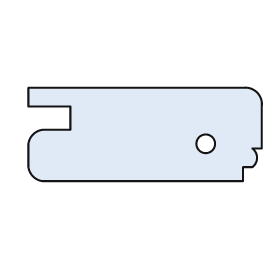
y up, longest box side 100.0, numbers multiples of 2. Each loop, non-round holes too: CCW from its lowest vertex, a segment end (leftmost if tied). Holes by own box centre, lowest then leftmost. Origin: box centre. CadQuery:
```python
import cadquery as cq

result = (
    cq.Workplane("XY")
    .moveTo(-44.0, -20.0)
    .lineTo(42.0, -20.0)
    .lineTo(42.0, -14.0)
    .lineTo(46.0, -14.0)
    .threePointArc((48.0, -10.0), (46.0, -6.0))
    .lineTo(50.0, -6.0)
    .lineTo(50.0, 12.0)
    .threePointArc((48.0, 18.0), (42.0, 20.0))
    .lineTo(-50.0, 20.0)
    .lineTo(-50.0, 12.0)
    .lineTo(-32.0, 12.0)
    .lineTo(-32.0, 2.0)
    .lineTo(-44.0, 2.0)
    .threePointArc((-48.0, 0.0), (-50.0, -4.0))
    .lineTo(-50.0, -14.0)
    .threePointArc((-48.0, -18.0), (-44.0, -20.0))
    .close()
    .moveTo(26.0, -4.0)
    .circle(4.0)
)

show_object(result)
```